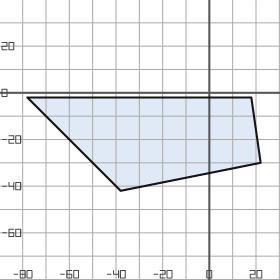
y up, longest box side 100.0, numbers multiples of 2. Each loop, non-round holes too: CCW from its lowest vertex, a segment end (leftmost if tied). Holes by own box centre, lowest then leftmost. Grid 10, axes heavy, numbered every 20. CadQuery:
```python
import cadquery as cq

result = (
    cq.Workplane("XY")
    .moveTo(-38.0, -42.0)
    .lineTo(22.0, -30.0)
    .lineTo(18.0, -2.0)
    .lineTo(-78.0, -2.0)
    .close()
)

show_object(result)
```